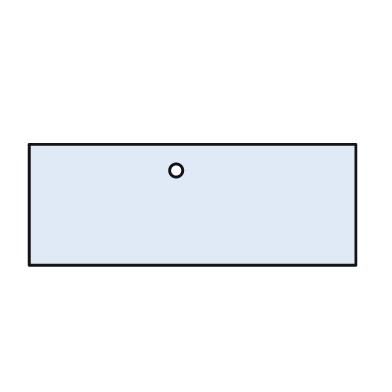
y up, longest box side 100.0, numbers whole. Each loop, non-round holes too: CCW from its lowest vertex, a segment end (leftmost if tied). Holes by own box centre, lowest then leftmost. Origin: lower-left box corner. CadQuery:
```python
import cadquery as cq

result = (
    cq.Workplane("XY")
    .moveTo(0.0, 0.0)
    .lineTo(100.0, 0.0)
    .lineTo(100.0, 37.0)
    .lineTo(0.0, 37.0)
    .close()
    .moveTo(45.0, 29.0)
    .circle(2.0)
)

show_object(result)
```